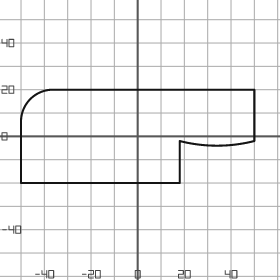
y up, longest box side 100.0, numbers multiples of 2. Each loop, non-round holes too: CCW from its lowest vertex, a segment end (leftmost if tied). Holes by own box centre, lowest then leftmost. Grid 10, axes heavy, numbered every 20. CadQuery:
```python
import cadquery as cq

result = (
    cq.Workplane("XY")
    .moveTo(-50.0, -20.0)
    .lineTo(18.0, -20.0)
    .lineTo(18.0, -2.0)
    .threePointArc((34.0, -4.0), (50.0, -2.0))
    .lineTo(50.0, 20.0)
    .lineTo(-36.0, 20.0)
    .threePointArc((-46.0, 16.0), (-50.0, 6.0))
    .close()
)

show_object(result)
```